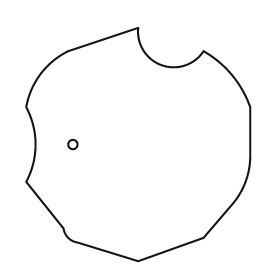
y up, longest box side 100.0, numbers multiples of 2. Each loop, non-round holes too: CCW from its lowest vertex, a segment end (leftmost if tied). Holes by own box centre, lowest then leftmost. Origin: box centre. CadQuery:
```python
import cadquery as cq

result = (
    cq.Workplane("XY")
    .moveTo(0.0, -50.0)
    .lineTo(28.0, -40.0)
    .lineTo(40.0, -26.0)
    .threePointArc((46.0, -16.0), (48.0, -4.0))
    .lineTo(48.0, 16.0)
    .threePointArc((40.0, 30.0), (28.0, 40.0))
    .threePointArc((10.0, 34.0), (0.0, 50.0))
    .lineTo(-30.0, 40.0)
    .threePointArc((-42.0, 30.0), (-48.0, 16.0))
    .threePointArc((-44.0, 0.0), (-48.0, -16.0))
    .lineTo(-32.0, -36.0)
    .threePointArc((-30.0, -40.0), (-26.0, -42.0))
    .close()
    .moveTo(-28.0, 0.0)
    .circle(2.0)
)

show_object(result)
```